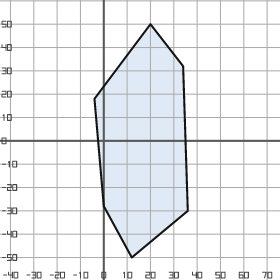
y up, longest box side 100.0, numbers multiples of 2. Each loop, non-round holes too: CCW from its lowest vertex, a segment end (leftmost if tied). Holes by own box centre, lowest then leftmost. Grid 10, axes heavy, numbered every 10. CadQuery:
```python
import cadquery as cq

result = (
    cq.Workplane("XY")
    .moveTo(12.0, -50.0)
    .lineTo(36.0, -30.0)
    .lineTo(34.0, 32.0)
    .lineTo(20.0, 50.0)
    .lineTo(-4.0, 18.0)
    .lineTo(0.0, -28.0)
    .close()
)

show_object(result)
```